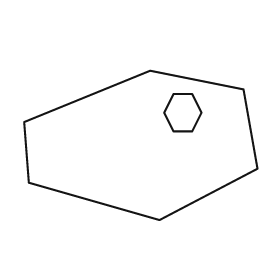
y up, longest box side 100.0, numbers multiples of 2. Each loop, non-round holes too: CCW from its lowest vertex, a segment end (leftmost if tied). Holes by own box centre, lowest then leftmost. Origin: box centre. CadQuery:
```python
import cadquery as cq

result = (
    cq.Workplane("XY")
    .moveTo(8.0, -32.0)
    .lineTo(50.0, -10.0)
    .lineTo(44.0, 24.0)
    .lineTo(4.0, 32.0)
    .lineTo(-50.0, 10.0)
    .lineTo(-48.0, -16.0)
    .close()
    .moveTo(14.0, 6.0)
    .lineTo(22.0, 6.0)
    .lineTo(26.0, 14.0)
    .lineTo(22.0, 22.0)
    .lineTo(14.0, 22.0)
    .lineTo(10.0, 14.0)
    .close()
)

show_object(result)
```